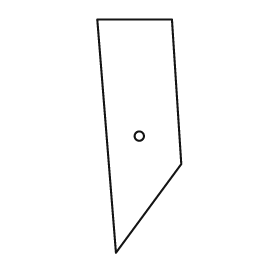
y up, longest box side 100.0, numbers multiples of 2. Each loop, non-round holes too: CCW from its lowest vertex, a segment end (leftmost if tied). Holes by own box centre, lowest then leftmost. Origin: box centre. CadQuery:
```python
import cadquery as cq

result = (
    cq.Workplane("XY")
    .moveTo(-10.0, -50.0)
    .lineTo(18.0, -12.0)
    .lineTo(14.0, 50.0)
    .lineTo(-18.0, 50.0)
    .close()
    .moveTo(0.0, 0.0)
    .circle(2.0)
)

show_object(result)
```